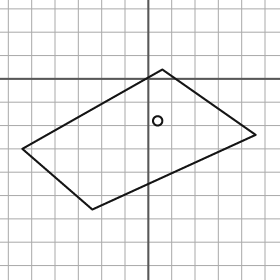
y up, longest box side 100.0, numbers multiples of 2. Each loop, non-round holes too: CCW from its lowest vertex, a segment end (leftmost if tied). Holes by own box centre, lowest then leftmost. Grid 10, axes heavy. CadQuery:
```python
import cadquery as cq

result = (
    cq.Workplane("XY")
    .moveTo(-24.0, -56.0)
    .lineTo(46.0, -24.0)
    .lineTo(6.0, 4.0)
    .lineTo(-54.0, -30.0)
    .close()
    .moveTo(4.0, -18.0)
    .circle(2.0)
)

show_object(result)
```